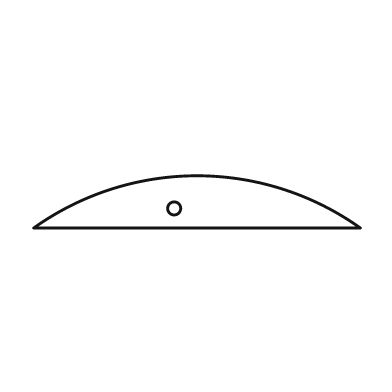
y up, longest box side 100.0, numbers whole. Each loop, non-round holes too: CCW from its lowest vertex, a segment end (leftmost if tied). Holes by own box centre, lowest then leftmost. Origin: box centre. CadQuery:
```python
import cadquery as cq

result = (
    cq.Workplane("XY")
    .moveTo(-50.0, -8.0)
    .lineTo(50.0, -8.0)
    .threePointArc((0.0, 8.0), (-50.0, -8.0))
    .close()
    .moveTo(-7.0, -2.0)
    .circle(2.0)
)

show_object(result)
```